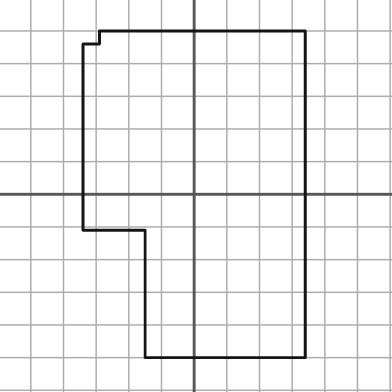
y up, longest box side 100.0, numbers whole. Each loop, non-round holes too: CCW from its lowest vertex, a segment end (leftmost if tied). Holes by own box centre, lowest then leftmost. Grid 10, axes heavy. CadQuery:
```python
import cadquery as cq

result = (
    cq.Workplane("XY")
    .moveTo(-15.0, -50.0)
    .lineTo(34.0, -50.0)
    .lineTo(34.0, 50.0)
    .lineTo(-29.0, 50.0)
    .lineTo(-29.0, 46.0)
    .lineTo(-34.0, 46.0)
    .lineTo(-34.0, -11.0)
    .lineTo(-15.0, -11.0)
    .close()
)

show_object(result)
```